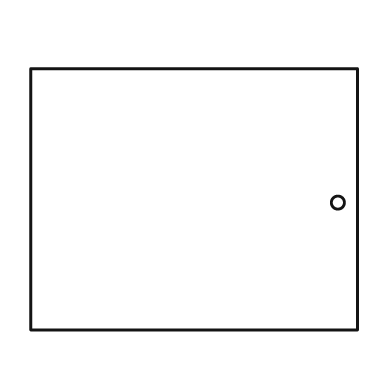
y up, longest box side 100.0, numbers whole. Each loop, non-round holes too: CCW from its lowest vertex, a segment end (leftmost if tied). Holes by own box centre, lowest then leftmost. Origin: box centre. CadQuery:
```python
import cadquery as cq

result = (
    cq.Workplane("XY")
    .moveTo(-50.0, -40.0)
    .lineTo(50.0, -40.0)
    .lineTo(50.0, 40.0)
    .lineTo(-50.0, 40.0)
    .close()
    .moveTo(44.0, -1.0)
    .circle(2.0)
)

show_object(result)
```